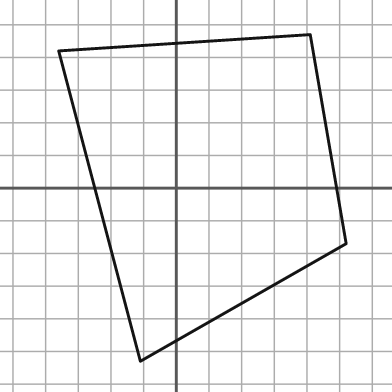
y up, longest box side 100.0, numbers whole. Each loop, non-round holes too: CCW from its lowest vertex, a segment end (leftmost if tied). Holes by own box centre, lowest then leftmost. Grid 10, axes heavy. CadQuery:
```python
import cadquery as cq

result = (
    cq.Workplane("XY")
    .moveTo(-11.0, -53.0)
    .lineTo(52.0, -17.0)
    .lineTo(41.0, 47.0)
    .lineTo(-36.0, 42.0)
    .close()
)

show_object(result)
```